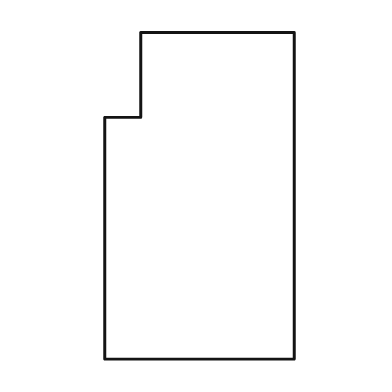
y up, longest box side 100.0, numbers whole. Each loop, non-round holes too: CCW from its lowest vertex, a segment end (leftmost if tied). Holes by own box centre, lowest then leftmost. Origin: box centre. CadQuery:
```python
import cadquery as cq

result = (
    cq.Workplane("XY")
    .moveTo(-29.0, -50.0)
    .lineTo(29.0, -50.0)
    .lineTo(29.0, 50.0)
    .lineTo(-18.0, 50.0)
    .lineTo(-18.0, 24.0)
    .lineTo(-29.0, 24.0)
    .close()
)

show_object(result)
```